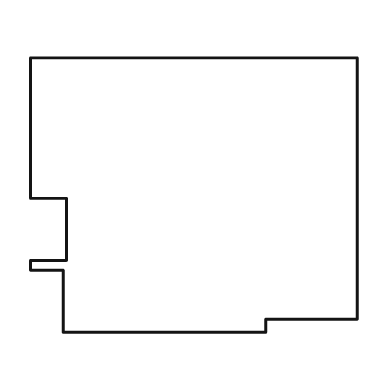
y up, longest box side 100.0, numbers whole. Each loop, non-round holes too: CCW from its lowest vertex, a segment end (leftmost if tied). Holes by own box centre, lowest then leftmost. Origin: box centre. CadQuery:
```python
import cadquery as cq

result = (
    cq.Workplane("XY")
    .moveTo(-40.0, -42.0)
    .lineTo(22.0, -42.0)
    .lineTo(22.0, -38.0)
    .lineTo(50.0, -38.0)
    .lineTo(50.0, 42.0)
    .lineTo(-50.0, 42.0)
    .lineTo(-50.0, -1.0)
    .lineTo(-39.0, -1.0)
    .lineTo(-39.0, -20.0)
    .lineTo(-50.0, -20.0)
    .lineTo(-50.0, -23.0)
    .lineTo(-40.0, -23.0)
    .close()
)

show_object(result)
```